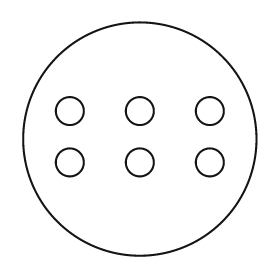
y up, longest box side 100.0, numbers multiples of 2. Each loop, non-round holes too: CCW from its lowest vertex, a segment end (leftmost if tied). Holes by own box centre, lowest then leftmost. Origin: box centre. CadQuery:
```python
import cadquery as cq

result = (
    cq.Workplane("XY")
    .moveTo(0.0, 0.0)
    .circle(50.0)
    .moveTo(-30.0, -10.0)
    .circle(6.0)
    .moveTo(0.0, -10.0)
    .circle(6.0)
    .moveTo(30.0, -10.0)
    .circle(6.0)
    .moveTo(-30.0, 12.0)
    .circle(6.0)
    .moveTo(0.0, 12.0)
    .circle(6.0)
    .moveTo(30.0, 12.0)
    .circle(6.0)
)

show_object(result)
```